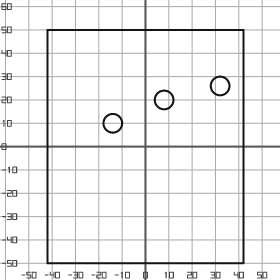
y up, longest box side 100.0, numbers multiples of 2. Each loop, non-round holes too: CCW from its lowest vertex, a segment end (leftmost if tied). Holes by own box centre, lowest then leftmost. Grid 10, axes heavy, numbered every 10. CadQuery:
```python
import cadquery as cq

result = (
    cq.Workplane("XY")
    .moveTo(-42.0, -50.0)
    .lineTo(42.0, -50.0)
    .lineTo(42.0, 50.0)
    .lineTo(-42.0, 50.0)
    .close()
    .moveTo(-14.0, 10.0)
    .circle(4.0)
    .moveTo(8.0, 20.0)
    .circle(4.0)
    .moveTo(32.0, 26.0)
    .circle(4.0)
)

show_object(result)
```